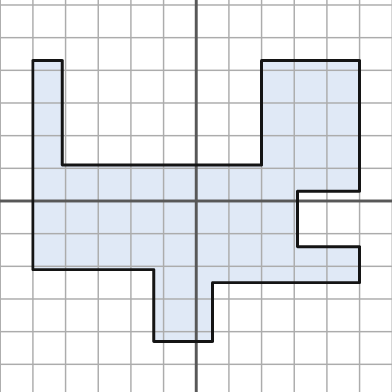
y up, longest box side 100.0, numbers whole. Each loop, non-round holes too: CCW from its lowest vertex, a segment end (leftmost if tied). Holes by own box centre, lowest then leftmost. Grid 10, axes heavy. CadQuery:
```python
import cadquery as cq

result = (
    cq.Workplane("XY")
    .moveTo(-13.0, -43.0)
    .lineTo(5.0, -43.0)
    .lineTo(5.0, -25.0)
    .lineTo(50.0, -25.0)
    .lineTo(50.0, -14.0)
    .lineTo(31.0, -14.0)
    .lineTo(31.0, 3.0)
    .lineTo(50.0, 3.0)
    .lineTo(50.0, 43.0)
    .lineTo(20.0, 43.0)
    .lineTo(20.0, 11.0)
    .lineTo(-41.0, 11.0)
    .lineTo(-41.0, 43.0)
    .lineTo(-50.0, 43.0)
    .lineTo(-50.0, -21.0)
    .lineTo(-13.0, -21.0)
    .close()
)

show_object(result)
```